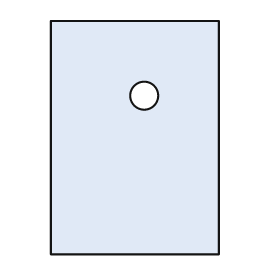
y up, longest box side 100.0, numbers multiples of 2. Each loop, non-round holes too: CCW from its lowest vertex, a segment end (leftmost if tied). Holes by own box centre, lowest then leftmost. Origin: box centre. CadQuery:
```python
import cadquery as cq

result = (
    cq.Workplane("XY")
    .moveTo(-36.0, -50.0)
    .lineTo(36.0, -50.0)
    .lineTo(36.0, 50.0)
    .lineTo(-36.0, 50.0)
    .close()
    .moveTo(4.0, 18.0)
    .circle(6.0)
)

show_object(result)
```